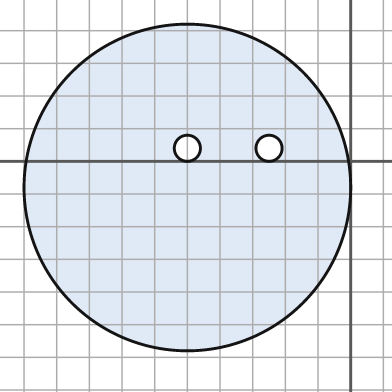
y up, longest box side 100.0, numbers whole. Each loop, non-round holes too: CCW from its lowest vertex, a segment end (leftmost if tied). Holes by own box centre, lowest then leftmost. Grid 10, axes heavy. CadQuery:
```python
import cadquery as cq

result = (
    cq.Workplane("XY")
    .moveTo(-50.0, -8.0)
    .circle(50.0)
    .moveTo(-50.0, 4.0)
    .circle(4.0)
    .moveTo(-25.0, 4.0)
    .circle(4.0)
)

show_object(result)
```